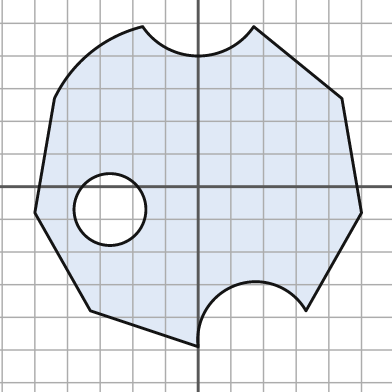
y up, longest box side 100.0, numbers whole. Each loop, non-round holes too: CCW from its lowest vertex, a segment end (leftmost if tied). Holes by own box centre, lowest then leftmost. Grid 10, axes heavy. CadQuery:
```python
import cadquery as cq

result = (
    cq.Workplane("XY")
    .moveTo(0.0, -49.0)
    .threePointArc((12.0, -30.0), (33.0, -38.0))
    .lineTo(50.0, -8.0)
    .lineTo(44.0, 27.0)
    .lineTo(17.0, 49.0)
    .threePointArc((0.0, 40.0), (-17.0, 49.0))
    .threePointArc((-33.0, 41.0), (-44.0, 27.0))
    .lineTo(-50.0, -8.0)
    .lineTo(-33.0, -38.0)
    .close()
    .moveTo(-27.0, -7.0)
    .circle(11.0)
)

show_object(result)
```